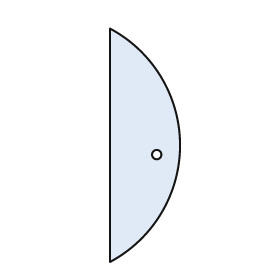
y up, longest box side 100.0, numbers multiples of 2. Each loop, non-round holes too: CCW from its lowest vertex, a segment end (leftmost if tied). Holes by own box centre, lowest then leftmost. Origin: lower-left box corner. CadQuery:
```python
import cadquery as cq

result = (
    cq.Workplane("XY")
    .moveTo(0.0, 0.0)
    .threePointArc((30.0, 50.0), (0.0, 100.0))
    .close()
    .moveTo(20.0, 46.0)
    .circle(2.0)
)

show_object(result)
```